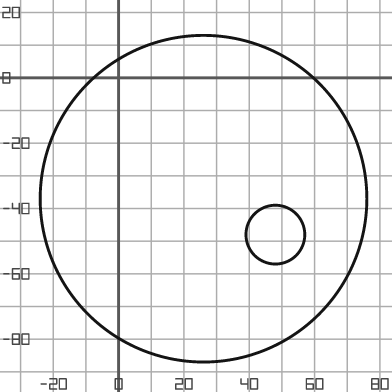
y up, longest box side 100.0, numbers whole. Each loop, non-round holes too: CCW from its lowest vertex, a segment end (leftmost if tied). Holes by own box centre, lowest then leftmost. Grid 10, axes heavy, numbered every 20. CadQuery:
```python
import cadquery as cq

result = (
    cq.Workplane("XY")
    .moveTo(26.0, -37.0)
    .circle(50.0)
    .moveTo(48.0, -48.0)
    .circle(9.0)
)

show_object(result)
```